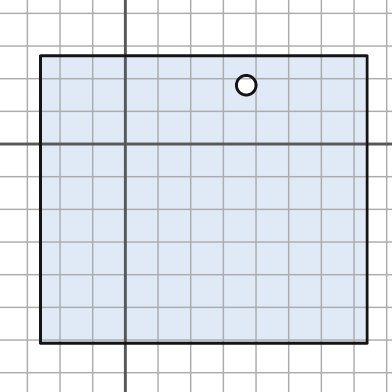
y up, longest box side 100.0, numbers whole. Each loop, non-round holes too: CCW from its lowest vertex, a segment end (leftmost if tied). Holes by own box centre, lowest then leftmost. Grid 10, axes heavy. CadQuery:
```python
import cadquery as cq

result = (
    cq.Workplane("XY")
    .moveTo(-26.0, -61.0)
    .lineTo(74.0, -61.0)
    .lineTo(74.0, 27.0)
    .lineTo(-26.0, 27.0)
    .close()
    .moveTo(37.0, 18.0)
    .circle(3.0)
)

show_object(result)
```